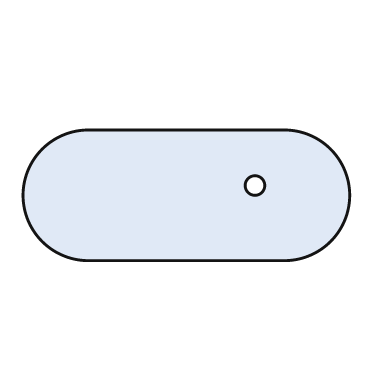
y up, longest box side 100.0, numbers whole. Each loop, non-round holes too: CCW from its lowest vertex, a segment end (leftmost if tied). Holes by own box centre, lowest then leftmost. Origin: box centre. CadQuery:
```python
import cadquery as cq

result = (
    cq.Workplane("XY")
    .moveTo(-30.0, -20.0)
    .lineTo(30.0, -20.0)
    .threePointArc((50.0, 0.0), (30.0, 20.0))
    .lineTo(-30.0, 20.0)
    .threePointArc((-50.0, 0.0), (-30.0, -20.0))
    .close()
    .moveTo(21.0, 3.0)
    .circle(3.0)
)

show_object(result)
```